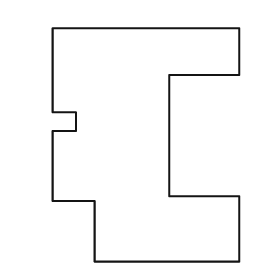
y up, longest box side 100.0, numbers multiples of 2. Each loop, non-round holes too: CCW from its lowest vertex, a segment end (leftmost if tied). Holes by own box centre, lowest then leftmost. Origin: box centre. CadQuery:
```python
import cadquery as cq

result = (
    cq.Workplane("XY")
    .moveTo(-22.0, -50.0)
    .lineTo(40.0, -50.0)
    .lineTo(40.0, -22.0)
    .lineTo(10.0, -22.0)
    .lineTo(10.0, 30.0)
    .lineTo(40.0, 30.0)
    .lineTo(40.0, 50.0)
    .lineTo(-40.0, 50.0)
    .lineTo(-40.0, 14.0)
    .lineTo(-30.0, 14.0)
    .lineTo(-30.0, 6.0)
    .lineTo(-40.0, 6.0)
    .lineTo(-40.0, -24.0)
    .lineTo(-22.0, -24.0)
    .close()
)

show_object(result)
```